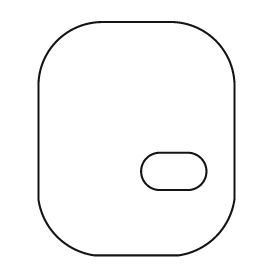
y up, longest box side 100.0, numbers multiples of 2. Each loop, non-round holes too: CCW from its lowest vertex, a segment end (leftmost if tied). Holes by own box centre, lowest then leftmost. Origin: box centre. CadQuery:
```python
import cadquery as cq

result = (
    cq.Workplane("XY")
    .moveTo(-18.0, -50.0)
    .lineTo(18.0, -50.0)
    .threePointArc((34.0, -42.0), (42.0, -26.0))
    .lineTo(42.0, 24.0)
    .threePointArc((34.0, 42.0), (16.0, 50.0))
    .lineTo(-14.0, 50.0)
    .threePointArc((-34.0, 42.0), (-42.0, 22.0))
    .lineTo(-42.0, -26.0)
    .threePointArc((-34.0, -42.0), (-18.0, -50.0))
    .close()
    .moveTo(10.0, -22.0)
    .lineTo(22.0, -22.0)
    .threePointArc((30.0, -14.0), (22.0, -6.0))
    .lineTo(10.0, -6.0)
    .threePointArc((2.0, -14.0), (10.0, -22.0))
    .close()
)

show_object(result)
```